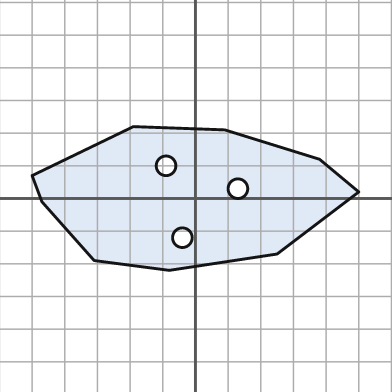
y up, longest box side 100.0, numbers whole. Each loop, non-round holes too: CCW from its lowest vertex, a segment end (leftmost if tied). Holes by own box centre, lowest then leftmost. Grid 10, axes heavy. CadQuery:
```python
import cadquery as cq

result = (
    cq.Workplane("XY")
    .moveTo(-8.0, -22.0)
    .lineTo(25.0, -17.0)
    .lineTo(50.0, 2.0)
    .lineTo(38.0, 12.0)
    .lineTo(9.0, 21.0)
    .lineTo(-19.0, 22.0)
    .lineTo(-50.0, 7.0)
    .lineTo(-47.0, -1.0)
    .lineTo(-31.0, -19.0)
    .close()
    .moveTo(-4.0, -12.0)
    .circle(3.0)
    .moveTo(13.0, 3.0)
    .circle(3.0)
    .moveTo(-9.0, 10.0)
    .circle(3.0)
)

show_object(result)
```